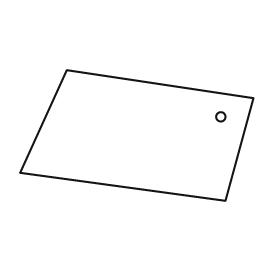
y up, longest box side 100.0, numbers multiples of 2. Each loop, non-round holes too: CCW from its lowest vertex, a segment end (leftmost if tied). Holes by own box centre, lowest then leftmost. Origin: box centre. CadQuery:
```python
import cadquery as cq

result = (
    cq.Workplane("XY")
    .moveTo(38.0, -28.0)
    .lineTo(50.0, 16.0)
    .lineTo(-30.0, 28.0)
    .lineTo(-50.0, -16.0)
    .close()
    .moveTo(36.0, 8.0)
    .circle(2.0)
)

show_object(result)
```